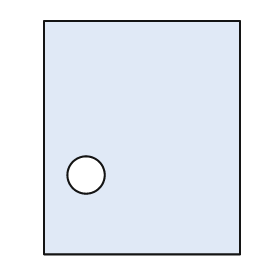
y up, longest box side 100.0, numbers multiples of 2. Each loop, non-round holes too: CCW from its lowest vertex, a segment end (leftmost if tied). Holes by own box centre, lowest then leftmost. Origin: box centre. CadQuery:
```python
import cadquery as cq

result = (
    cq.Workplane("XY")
    .moveTo(-42.0, -50.0)
    .lineTo(42.0, -50.0)
    .lineTo(42.0, 50.0)
    .lineTo(-42.0, 50.0)
    .close()
    .moveTo(-24.0, -16.0)
    .circle(8.0)
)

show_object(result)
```